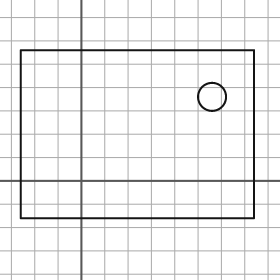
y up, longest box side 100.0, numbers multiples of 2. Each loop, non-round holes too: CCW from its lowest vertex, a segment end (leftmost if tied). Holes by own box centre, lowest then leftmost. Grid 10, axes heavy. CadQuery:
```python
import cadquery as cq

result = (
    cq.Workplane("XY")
    .moveTo(-26.0, -16.0)
    .lineTo(74.0, -16.0)
    .lineTo(74.0, 56.0)
    .lineTo(-26.0, 56.0)
    .close()
    .moveTo(56.0, 36.0)
    .circle(6.0)
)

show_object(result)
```